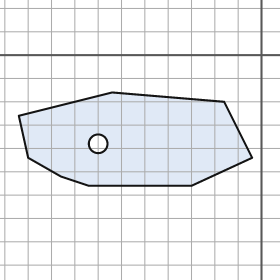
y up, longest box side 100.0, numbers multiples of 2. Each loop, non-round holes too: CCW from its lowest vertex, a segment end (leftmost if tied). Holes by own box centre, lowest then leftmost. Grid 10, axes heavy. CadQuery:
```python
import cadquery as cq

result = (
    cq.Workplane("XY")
    .moveTo(-74.0, -56.0)
    .lineTo(-30.0, -56.0)
    .lineTo(-4.0, -44.0)
    .lineTo(-16.0, -20.0)
    .lineTo(-64.0, -16.0)
    .lineTo(-104.0, -26.0)
    .lineTo(-100.0, -44.0)
    .lineTo(-86.0, -52.0)
    .close()
    .moveTo(-70.0, -38.0)
    .circle(4.0)
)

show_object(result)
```